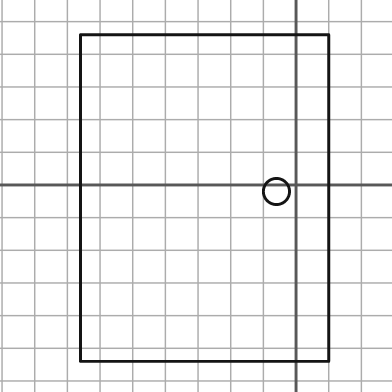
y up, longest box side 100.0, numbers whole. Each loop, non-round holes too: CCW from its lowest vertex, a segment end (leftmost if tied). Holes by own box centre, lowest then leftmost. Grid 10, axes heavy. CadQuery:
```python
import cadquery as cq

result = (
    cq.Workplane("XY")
    .moveTo(-66.0, -54.0)
    .lineTo(10.0, -54.0)
    .lineTo(10.0, 46.0)
    .lineTo(-66.0, 46.0)
    .close()
    .moveTo(-6.0, -2.0)
    .circle(4.0)
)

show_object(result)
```